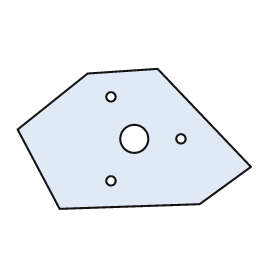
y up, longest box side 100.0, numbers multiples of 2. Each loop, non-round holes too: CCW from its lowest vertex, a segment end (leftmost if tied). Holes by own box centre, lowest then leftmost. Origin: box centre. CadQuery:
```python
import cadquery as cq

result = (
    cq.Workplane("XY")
    .moveTo(-32.0, -30.0)
    .lineTo(28.0, -28.0)
    .lineTo(50.0, -12.0)
    .lineTo(10.0, 30.0)
    .lineTo(-20.0, 28.0)
    .lineTo(-50.0, 4.0)
    .close()
    .moveTo(-10.0, -18.0)
    .circle(2.0)
    .moveTo(0.0, 0.0)
    .circle(6.0)
    .moveTo(20.0, 0.0)
    .circle(2.0)
    .moveTo(-10.0, 18.0)
    .circle(2.0)
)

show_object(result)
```